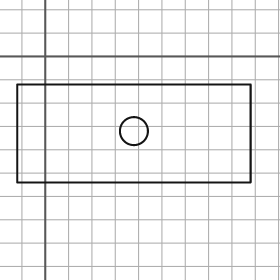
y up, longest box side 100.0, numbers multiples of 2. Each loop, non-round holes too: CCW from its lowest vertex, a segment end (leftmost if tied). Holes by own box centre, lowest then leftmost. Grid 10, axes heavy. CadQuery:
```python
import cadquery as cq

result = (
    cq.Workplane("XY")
    .moveTo(-12.0, -54.0)
    .lineTo(88.0, -54.0)
    .lineTo(88.0, -12.0)
    .lineTo(-12.0, -12.0)
    .close()
    .moveTo(38.0, -32.0)
    .circle(6.0)
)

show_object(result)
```